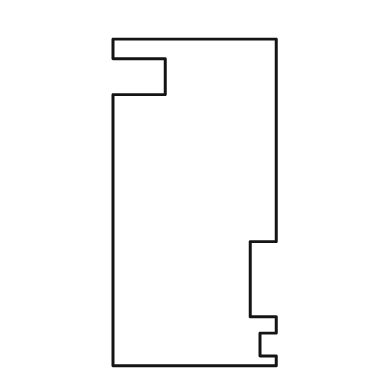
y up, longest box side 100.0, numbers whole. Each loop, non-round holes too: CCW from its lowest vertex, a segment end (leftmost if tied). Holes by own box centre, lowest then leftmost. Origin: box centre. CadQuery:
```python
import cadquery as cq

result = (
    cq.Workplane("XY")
    .moveTo(-25.0, -50.0)
    .lineTo(25.0, -50.0)
    .lineTo(25.0, -47.0)
    .lineTo(20.0, -47.0)
    .lineTo(20.0, -40.0)
    .lineTo(25.0, -40.0)
    .lineTo(25.0, -35.0)
    .lineTo(17.0, -35.0)
    .lineTo(17.0, -12.0)
    .lineTo(25.0, -12.0)
    .lineTo(25.0, 50.0)
    .lineTo(-25.0, 50.0)
    .lineTo(-25.0, 44.0)
    .lineTo(-9.0, 44.0)
    .lineTo(-9.0, 33.0)
    .lineTo(-25.0, 33.0)
    .close()
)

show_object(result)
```